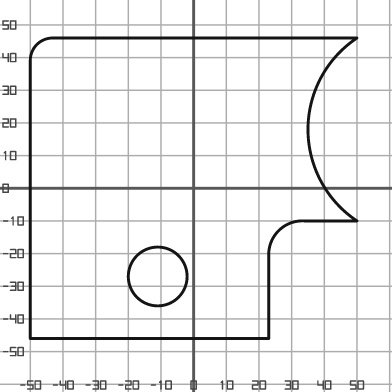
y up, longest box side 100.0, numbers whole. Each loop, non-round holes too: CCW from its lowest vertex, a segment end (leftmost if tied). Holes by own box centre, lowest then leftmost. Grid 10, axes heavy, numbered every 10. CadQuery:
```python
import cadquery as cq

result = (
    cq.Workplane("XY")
    .moveTo(-50.0, -46.0)
    .lineTo(23.0, -46.0)
    .lineTo(23.0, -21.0)
    .threePointArc((26.0, -13.0), (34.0, -10.0))
    .lineTo(50.0, -10.0)
    .threePointArc((35.0, 18.0), (50.0, 46.0))
    .lineTo(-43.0, 46.0)
    .threePointArc((-48.0, 44.0), (-50.0, 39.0))
    .close()
    .moveTo(-11.0, -27.0)
    .circle(9.0)
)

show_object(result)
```